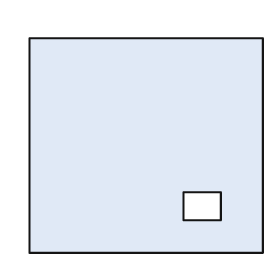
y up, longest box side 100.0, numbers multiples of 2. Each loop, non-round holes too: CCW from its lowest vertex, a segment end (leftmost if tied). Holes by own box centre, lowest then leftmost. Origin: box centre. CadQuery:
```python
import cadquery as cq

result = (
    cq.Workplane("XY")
    .moveTo(-50.0, -46.0)
    .lineTo(50.0, -46.0)
    .lineTo(50.0, 46.0)
    .lineTo(-50.0, 46.0)
    .close()
    .moveTo(16.0, -32.0)
    .lineTo(32.0, -32.0)
    .lineTo(32.0, -20.0)
    .lineTo(16.0, -20.0)
    .close()
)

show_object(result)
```